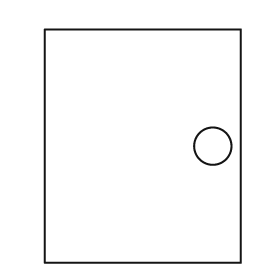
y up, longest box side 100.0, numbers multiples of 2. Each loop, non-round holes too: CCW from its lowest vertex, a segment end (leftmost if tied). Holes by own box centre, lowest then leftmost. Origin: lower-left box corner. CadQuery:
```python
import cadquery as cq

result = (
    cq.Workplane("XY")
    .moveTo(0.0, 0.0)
    .lineTo(84.0, 0.0)
    .lineTo(84.0, 100.0)
    .lineTo(0.0, 100.0)
    .close()
    .moveTo(72.0, 50.0)
    .circle(8.0)
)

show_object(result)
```